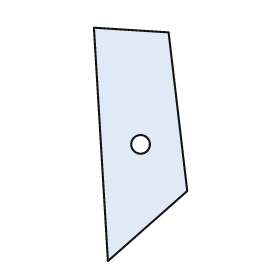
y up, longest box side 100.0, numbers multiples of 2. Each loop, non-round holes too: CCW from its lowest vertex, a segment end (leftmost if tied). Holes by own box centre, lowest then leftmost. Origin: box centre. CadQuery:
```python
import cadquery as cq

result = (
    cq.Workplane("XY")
    .moveTo(-14.0, -50.0)
    .lineTo(20.0, -20.0)
    .lineTo(12.0, 48.0)
    .lineTo(-20.0, 50.0)
    .close()
    .moveTo(0.0, 0.0)
    .circle(4.0)
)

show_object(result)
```